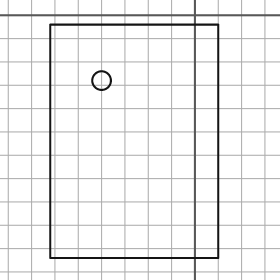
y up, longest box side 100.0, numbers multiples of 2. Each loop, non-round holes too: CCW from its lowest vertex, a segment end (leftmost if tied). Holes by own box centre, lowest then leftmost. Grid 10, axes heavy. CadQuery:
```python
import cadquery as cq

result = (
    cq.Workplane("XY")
    .moveTo(-62.0, -104.0)
    .lineTo(10.0, -104.0)
    .lineTo(10.0, -4.0)
    .lineTo(-62.0, -4.0)
    .close()
    .moveTo(-40.0, -28.0)
    .circle(4.0)
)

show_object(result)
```